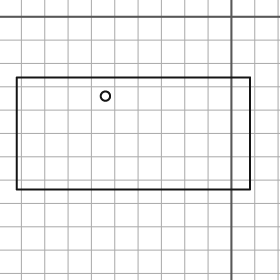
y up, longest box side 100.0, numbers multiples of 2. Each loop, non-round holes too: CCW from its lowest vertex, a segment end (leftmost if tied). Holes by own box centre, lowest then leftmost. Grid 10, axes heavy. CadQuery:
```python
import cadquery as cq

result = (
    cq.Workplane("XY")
    .moveTo(-92.0, -74.0)
    .lineTo(8.0, -74.0)
    .lineTo(8.0, -26.0)
    .lineTo(-92.0, -26.0)
    .close()
    .moveTo(-54.0, -34.0)
    .circle(2.0)
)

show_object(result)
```